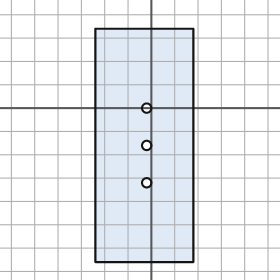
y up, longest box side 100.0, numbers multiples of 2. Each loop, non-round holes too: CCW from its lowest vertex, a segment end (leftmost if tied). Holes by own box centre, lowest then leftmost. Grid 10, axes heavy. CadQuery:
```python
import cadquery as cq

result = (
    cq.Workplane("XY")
    .moveTo(-24.0, -66.0)
    .lineTo(18.0, -66.0)
    .lineTo(18.0, 34.0)
    .lineTo(-24.0, 34.0)
    .close()
    .moveTo(-2.0, -32.0)
    .circle(2.0)
    .moveTo(-2.0, -16.0)
    .circle(2.0)
    .moveTo(-2.0, 0.0)
    .circle(2.0)
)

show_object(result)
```